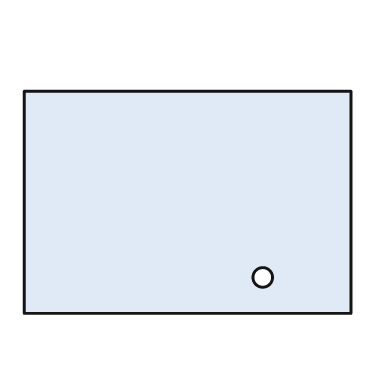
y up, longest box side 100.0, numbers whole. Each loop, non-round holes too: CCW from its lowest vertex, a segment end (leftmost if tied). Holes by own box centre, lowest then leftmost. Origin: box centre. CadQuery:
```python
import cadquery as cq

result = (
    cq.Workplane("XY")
    .moveTo(-50.0, -34.0)
    .lineTo(50.0, -34.0)
    .lineTo(50.0, 34.0)
    .lineTo(-50.0, 34.0)
    .close()
    .moveTo(23.0, -23.0)
    .circle(3.0)
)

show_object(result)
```